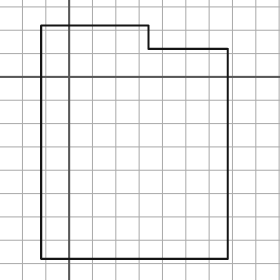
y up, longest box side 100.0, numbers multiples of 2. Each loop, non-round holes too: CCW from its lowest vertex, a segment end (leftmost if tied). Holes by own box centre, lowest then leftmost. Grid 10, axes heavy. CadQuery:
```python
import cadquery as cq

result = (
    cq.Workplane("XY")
    .moveTo(-12.0, -78.0)
    .lineTo(68.0, -78.0)
    .lineTo(68.0, 12.0)
    .lineTo(34.0, 12.0)
    .lineTo(34.0, 22.0)
    .lineTo(-12.0, 22.0)
    .close()
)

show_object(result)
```